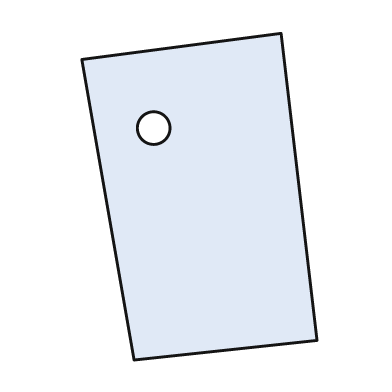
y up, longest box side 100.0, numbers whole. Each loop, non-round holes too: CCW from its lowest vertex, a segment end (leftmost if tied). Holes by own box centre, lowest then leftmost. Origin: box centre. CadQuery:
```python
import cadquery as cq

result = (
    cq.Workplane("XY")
    .moveTo(-20.0, -50.0)
    .lineTo(36.0, -44.0)
    .lineTo(25.0, 50.0)
    .lineTo(-36.0, 42.0)
    .close()
    .moveTo(-14.0, 21.0)
    .circle(5.0)
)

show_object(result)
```